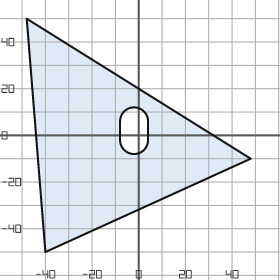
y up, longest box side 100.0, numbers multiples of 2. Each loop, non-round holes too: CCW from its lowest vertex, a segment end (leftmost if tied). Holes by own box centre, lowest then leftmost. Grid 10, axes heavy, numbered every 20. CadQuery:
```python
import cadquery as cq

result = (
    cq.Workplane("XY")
    .moveTo(-40.0, -50.0)
    .lineTo(48.0, -10.0)
    .lineTo(-48.0, 50.0)
    .close()
    .moveTo(-8.0, -2.0)
    .threePointArc((-2.0, -8.0), (4.0, -2.0))
    .lineTo(4.0, 6.0)
    .threePointArc((-2.0, 12.0), (-8.0, 6.0))
    .close()
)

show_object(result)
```